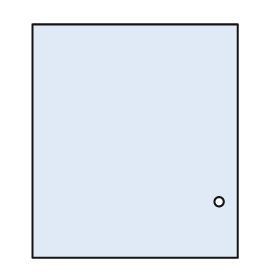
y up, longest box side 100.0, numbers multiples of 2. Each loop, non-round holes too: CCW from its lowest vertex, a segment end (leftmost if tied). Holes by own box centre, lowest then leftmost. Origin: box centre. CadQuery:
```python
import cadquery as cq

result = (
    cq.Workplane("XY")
    .moveTo(-44.0, -50.0)
    .lineTo(44.0, -50.0)
    .lineTo(44.0, 50.0)
    .lineTo(-44.0, 50.0)
    .close()
    .moveTo(36.0, -26.0)
    .circle(2.0)
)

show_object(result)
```